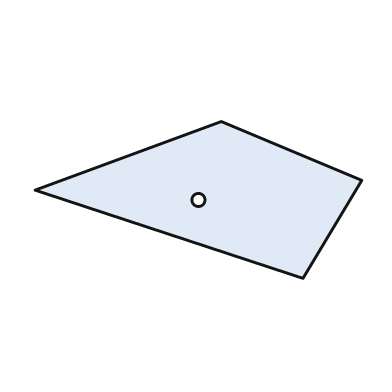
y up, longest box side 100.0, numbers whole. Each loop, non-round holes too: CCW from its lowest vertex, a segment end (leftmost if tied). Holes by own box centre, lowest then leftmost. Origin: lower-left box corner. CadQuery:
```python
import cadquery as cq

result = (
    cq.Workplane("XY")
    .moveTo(82.0, 0.0)
    .lineTo(100.0, 30.0)
    .lineTo(57.0, 48.0)
    .lineTo(0.0, 27.0)
    .close()
    .moveTo(50.0, 24.0)
    .circle(2.0)
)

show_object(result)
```